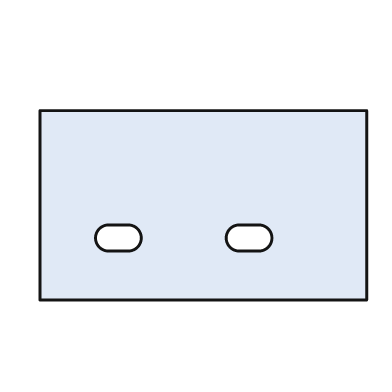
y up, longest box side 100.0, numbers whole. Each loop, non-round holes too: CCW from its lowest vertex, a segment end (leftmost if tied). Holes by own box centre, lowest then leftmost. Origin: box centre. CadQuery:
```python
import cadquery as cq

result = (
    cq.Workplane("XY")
    .moveTo(-50.0, -29.0)
    .lineTo(50.0, -29.0)
    .lineTo(50.0, 29.0)
    .lineTo(-50.0, 29.0)
    .close()
    .moveTo(-29.0, -14.0)
    .lineTo(-23.0, -14.0)
    .threePointArc((-19.0, -10.0), (-23.0, -6.0))
    .lineTo(-29.0, -6.0)
    .threePointArc((-33.0, -10.0), (-29.0, -14.0))
    .close()
    .moveTo(11.0, -14.0)
    .lineTo(17.0, -14.0)
    .threePointArc((21.0, -10.0), (17.0, -6.0))
    .lineTo(11.0, -6.0)
    .threePointArc((7.0, -10.0), (11.0, -14.0))
    .close()
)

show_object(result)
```